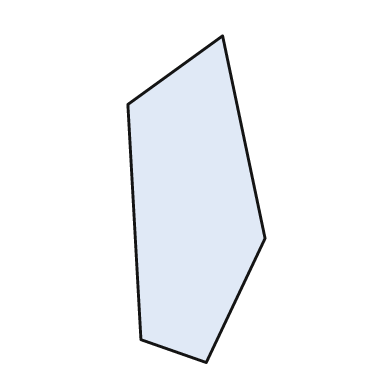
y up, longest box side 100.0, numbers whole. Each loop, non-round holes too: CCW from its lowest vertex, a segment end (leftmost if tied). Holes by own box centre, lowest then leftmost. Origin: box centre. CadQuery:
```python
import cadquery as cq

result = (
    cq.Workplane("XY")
    .moveTo(3.0, -50.0)
    .lineTo(21.0, -12.0)
    .lineTo(8.0, 50.0)
    .lineTo(-21.0, 29.0)
    .lineTo(-17.0, -43.0)
    .close()
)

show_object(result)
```